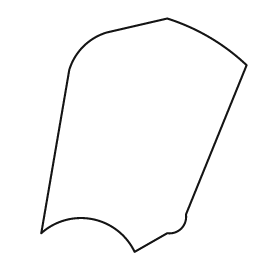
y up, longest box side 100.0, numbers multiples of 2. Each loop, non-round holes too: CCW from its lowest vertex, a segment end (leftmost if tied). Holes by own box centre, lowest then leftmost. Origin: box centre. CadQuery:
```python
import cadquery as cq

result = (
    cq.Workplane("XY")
    .moveTo(-4.0, -50.0)
    .lineTo(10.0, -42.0)
    .threePointArc((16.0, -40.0), (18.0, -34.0))
    .lineTo(44.0, 30.0)
    .threePointArc((28.0, 42.0), (10.0, 50.0))
    .lineTo(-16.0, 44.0)
    .threePointArc((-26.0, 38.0), (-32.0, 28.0))
    .lineTo(-44.0, -42.0)
    .threePointArc((-22.0, -36.0), (-4.0, -50.0))
    .close()
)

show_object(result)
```